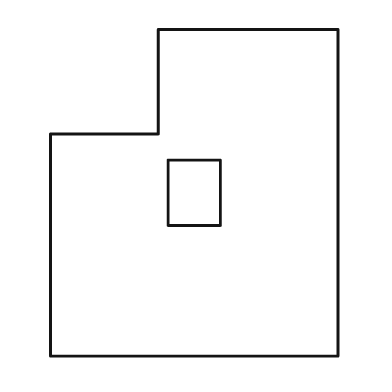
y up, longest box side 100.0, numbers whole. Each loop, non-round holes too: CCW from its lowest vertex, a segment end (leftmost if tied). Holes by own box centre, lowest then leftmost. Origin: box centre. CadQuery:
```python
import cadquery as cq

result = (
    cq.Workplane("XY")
    .moveTo(-44.0, -50.0)
    .lineTo(44.0, -50.0)
    .lineTo(44.0, 50.0)
    .lineTo(-11.0, 50.0)
    .lineTo(-11.0, 18.0)
    .lineTo(-44.0, 18.0)
    .close()
    .moveTo(-8.0, -10.0)
    .lineTo(8.0, -10.0)
    .lineTo(8.0, 10.0)
    .lineTo(-8.0, 10.0)
    .close()
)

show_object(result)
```